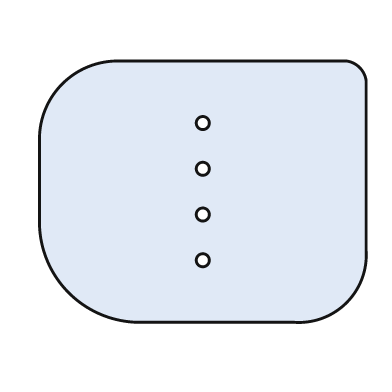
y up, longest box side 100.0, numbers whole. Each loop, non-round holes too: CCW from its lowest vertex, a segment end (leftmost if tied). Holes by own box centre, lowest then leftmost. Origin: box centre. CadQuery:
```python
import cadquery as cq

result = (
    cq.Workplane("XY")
    .moveTo(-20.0, -40.0)
    .lineTo(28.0, -40.0)
    .threePointArc((44.0, -34.0), (50.0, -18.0))
    .lineTo(50.0, 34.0)
    .threePointArc((48.0, 38.0), (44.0, 40.0))
    .lineTo(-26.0, 40.0)
    .threePointArc((-43.0, 33.0), (-50.0, 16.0))
    .lineTo(-50.0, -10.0)
    .threePointArc((-41.0, -31.0), (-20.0, -40.0))
    .close()
    .moveTo(0.0, -21.0)
    .circle(2.0)
    .moveTo(0.0, -7.0)
    .circle(2.0)
    .moveTo(0.0, 7.0)
    .circle(2.0)
    .moveTo(0.0, 21.0)
    .circle(2.0)
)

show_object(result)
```